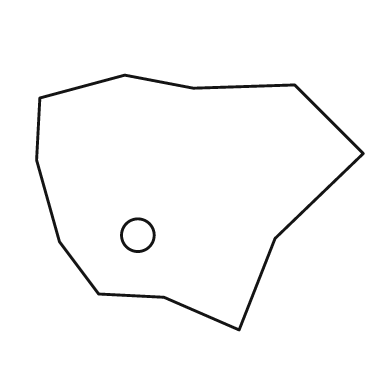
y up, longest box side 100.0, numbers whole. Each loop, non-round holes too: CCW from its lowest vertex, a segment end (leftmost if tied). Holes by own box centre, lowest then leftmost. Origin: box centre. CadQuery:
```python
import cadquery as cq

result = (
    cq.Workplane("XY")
    .moveTo(12.0, -39.0)
    .lineTo(23.0, -11.0)
    .lineTo(50.0, 15.0)
    .lineTo(29.0, 36.0)
    .lineTo(-2.0, 35.0)
    .lineTo(-23.0, 39.0)
    .lineTo(-49.0, 32.0)
    .lineTo(-50.0, 13.0)
    .lineTo(-43.0, -12.0)
    .lineTo(-31.0, -28.0)
    .lineTo(-11.0, -29.0)
    .close()
    .moveTo(-19.0, -10.0)
    .circle(5.0)
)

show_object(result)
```